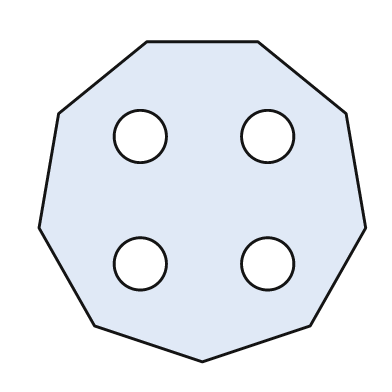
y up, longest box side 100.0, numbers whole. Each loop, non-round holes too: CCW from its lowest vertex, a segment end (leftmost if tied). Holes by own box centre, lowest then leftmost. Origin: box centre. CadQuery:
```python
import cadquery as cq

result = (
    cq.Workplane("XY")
    .moveTo(0.0, -49.0)
    .lineTo(33.0, -38.0)
    .lineTo(50.0, -8.0)
    .lineTo(44.0, 27.0)
    .lineTo(17.0, 49.0)
    .lineTo(-17.0, 49.0)
    .lineTo(-44.0, 27.0)
    .lineTo(-50.0, -8.0)
    .lineTo(-33.0, -38.0)
    .close()
    .moveTo(-19.0, -19.0)
    .circle(8.0)
    .moveTo(20.0, -19.0)
    .circle(8.0)
    .moveTo(-19.0, 20.0)
    .circle(8.0)
    .moveTo(20.0, 20.0)
    .circle(8.0)
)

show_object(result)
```